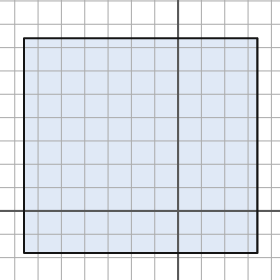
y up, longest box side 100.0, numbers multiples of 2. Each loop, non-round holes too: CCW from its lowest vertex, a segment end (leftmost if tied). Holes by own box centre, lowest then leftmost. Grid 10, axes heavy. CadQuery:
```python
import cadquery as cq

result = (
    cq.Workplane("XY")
    .moveTo(-66.0, -18.0)
    .lineTo(34.0, -18.0)
    .lineTo(34.0, 74.0)
    .lineTo(-66.0, 74.0)
    .close()
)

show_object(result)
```